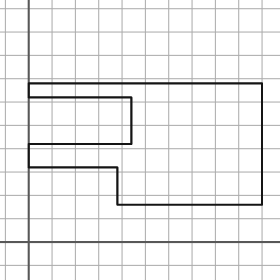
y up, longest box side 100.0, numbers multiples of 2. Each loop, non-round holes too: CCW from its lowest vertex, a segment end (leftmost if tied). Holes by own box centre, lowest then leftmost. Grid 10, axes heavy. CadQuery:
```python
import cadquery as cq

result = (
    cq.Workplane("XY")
    .moveTo(38.0, 16.0)
    .lineTo(100.0, 16.0)
    .lineTo(100.0, 68.0)
    .lineTo(0.0, 68.0)
    .lineTo(0.0, 62.0)
    .lineTo(44.0, 62.0)
    .lineTo(44.0, 42.0)
    .lineTo(0.0, 42.0)
    .lineTo(0.0, 32.0)
    .lineTo(38.0, 32.0)
    .close()
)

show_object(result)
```